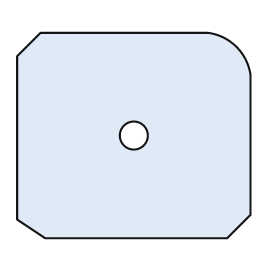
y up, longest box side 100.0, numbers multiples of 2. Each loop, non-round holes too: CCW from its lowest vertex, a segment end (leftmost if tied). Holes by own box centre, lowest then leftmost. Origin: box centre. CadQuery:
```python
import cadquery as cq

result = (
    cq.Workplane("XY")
    .moveTo(-38.0, -44.0)
    .lineTo(40.0, -44.0)
    .lineTo(50.0, -34.0)
    .lineTo(50.0, 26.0)
    .threePointArc((44.0, 38.0), (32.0, 44.0))
    .lineTo(-40.0, 44.0)
    .lineTo(-50.0, 34.0)
    .lineTo(-50.0, -36.0)
    .close()
    .moveTo(0.0, 0.0)
    .circle(6.0)
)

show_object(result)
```